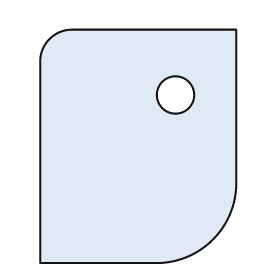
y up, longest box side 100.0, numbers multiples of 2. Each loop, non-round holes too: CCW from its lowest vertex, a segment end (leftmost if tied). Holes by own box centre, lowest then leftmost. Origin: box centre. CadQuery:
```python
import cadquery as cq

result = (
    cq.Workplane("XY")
    .moveTo(-42.0, -50.0)
    .lineTo(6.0, -50.0)
    .threePointArc((32.0, -40.0), (42.0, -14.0))
    .lineTo(42.0, 50.0)
    .lineTo(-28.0, 50.0)
    .threePointArc((-38.0, 46.0), (-42.0, 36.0))
    .close()
    .moveTo(16.0, 22.0)
    .circle(8.0)
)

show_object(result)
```